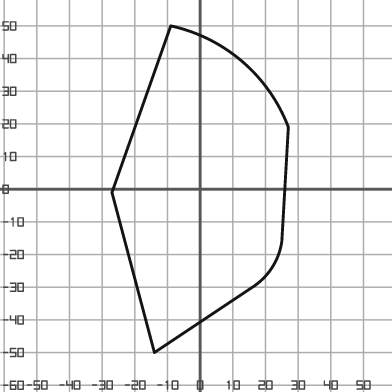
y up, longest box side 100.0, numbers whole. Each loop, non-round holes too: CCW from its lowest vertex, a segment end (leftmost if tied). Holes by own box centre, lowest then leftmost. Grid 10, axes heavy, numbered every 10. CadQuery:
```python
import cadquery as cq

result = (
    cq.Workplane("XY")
    .moveTo(-14.0, -50.0)
    .lineTo(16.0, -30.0)
    .threePointArc((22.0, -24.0), (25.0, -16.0))
    .lineTo(27.0, 19.0)
    .threePointArc((13.0, 39.0), (-9.0, 50.0))
    .lineTo(-27.0, -1.0)
    .close()
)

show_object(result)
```